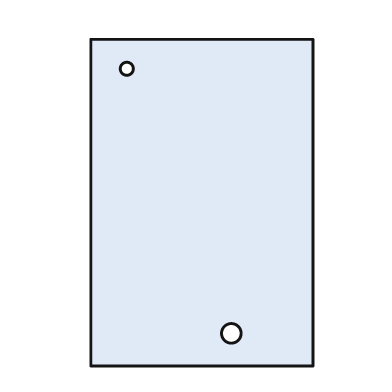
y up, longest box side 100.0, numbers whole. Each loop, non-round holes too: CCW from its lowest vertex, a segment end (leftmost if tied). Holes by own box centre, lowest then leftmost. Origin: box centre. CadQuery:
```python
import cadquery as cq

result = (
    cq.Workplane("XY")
    .moveTo(-34.0, -50.0)
    .lineTo(34.0, -50.0)
    .lineTo(34.0, 50.0)
    .lineTo(-34.0, 50.0)
    .close()
    .moveTo(9.0, -40.0)
    .circle(3.0)
    .moveTo(-23.0, 41.0)
    .circle(2.0)
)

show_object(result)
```